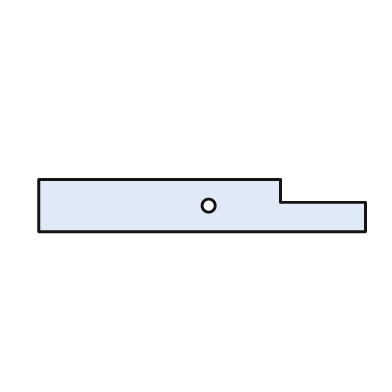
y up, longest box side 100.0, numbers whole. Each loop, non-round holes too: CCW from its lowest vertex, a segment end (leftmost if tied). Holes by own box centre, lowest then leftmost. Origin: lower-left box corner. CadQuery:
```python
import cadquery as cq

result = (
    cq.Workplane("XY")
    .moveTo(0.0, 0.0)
    .lineTo(100.0, 0.0)
    .lineTo(100.0, 9.0)
    .lineTo(74.0, 9.0)
    .lineTo(74.0, 16.0)
    .lineTo(0.0, 16.0)
    .close()
    .moveTo(52.0, 8.0)
    .circle(2.0)
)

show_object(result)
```